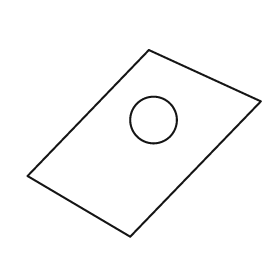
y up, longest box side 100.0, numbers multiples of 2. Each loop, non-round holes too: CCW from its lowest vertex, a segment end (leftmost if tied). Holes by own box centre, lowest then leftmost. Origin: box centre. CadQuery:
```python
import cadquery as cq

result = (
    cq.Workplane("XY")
    .moveTo(-6.0, -40.0)
    .lineTo(50.0, 18.0)
    .lineTo(2.0, 40.0)
    .lineTo(-50.0, -14.0)
    .close()
    .moveTo(4.0, 10.0)
    .circle(10.0)
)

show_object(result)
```